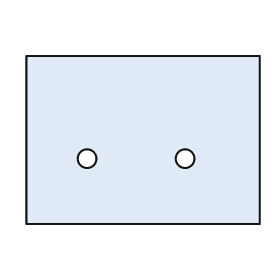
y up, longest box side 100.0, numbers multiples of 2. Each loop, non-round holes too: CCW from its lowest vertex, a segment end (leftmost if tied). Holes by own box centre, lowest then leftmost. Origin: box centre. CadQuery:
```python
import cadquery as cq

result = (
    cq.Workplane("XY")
    .moveTo(-50.0, -36.0)
    .lineTo(50.0, -36.0)
    .lineTo(50.0, 36.0)
    .lineTo(-50.0, 36.0)
    .close()
    .moveTo(-24.0, -8.0)
    .circle(4.0)
    .moveTo(18.0, -8.0)
    .circle(4.0)
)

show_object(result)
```